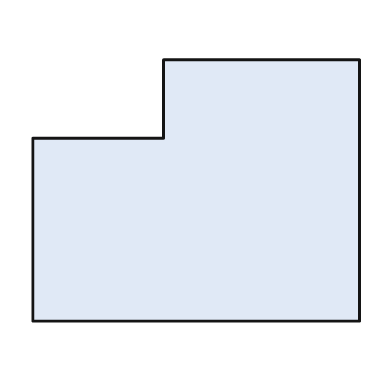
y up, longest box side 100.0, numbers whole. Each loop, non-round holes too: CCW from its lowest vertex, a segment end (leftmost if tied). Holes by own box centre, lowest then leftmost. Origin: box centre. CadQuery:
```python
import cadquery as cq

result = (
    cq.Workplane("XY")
    .moveTo(-50.0, -40.0)
    .lineTo(50.0, -40.0)
    .lineTo(50.0, 40.0)
    .lineTo(-10.0, 40.0)
    .lineTo(-10.0, 16.0)
    .lineTo(-50.0, 16.0)
    .close()
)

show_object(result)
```